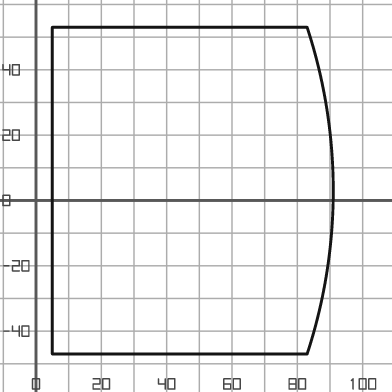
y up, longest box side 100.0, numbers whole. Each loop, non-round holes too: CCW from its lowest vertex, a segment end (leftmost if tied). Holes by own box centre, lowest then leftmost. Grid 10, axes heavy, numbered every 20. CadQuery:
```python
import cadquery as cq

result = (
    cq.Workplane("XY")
    .moveTo(5.0, -47.0)
    .lineTo(83.0, -47.0)
    .threePointArc((91.0, 3.0), (83.0, 53.0))
    .lineTo(5.0, 53.0)
    .close()
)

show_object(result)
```